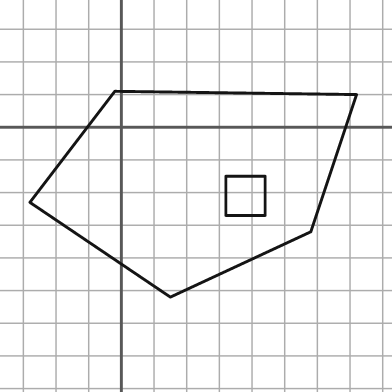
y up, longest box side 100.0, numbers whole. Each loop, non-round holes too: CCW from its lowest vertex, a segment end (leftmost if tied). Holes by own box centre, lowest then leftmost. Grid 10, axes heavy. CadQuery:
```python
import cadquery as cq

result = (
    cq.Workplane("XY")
    .moveTo(15.0, -52.0)
    .lineTo(58.0, -32.0)
    .lineTo(72.0, 10.0)
    .lineTo(-2.0, 11.0)
    .lineTo(-28.0, -23.0)
    .close()
    .moveTo(32.0, -27.0)
    .lineTo(44.0, -27.0)
    .lineTo(44.0, -15.0)
    .lineTo(32.0, -15.0)
    .close()
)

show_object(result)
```